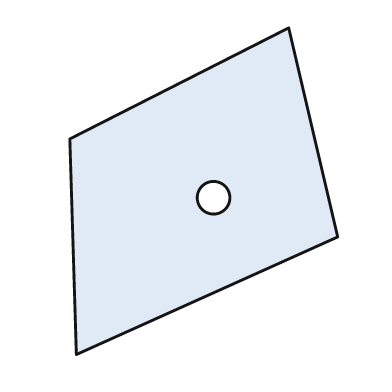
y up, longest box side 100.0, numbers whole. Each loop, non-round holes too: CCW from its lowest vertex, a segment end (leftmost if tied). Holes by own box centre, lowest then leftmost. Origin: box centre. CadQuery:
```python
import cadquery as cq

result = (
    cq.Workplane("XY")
    .moveTo(-39.0, -50.0)
    .lineTo(41.0, -14.0)
    .lineTo(26.0, 50.0)
    .lineTo(-41.0, 16.0)
    .close()
    .moveTo(3.0, -2.0)
    .circle(5.0)
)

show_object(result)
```